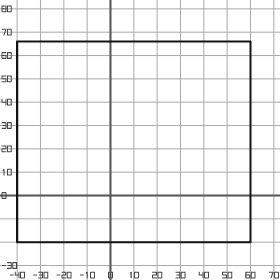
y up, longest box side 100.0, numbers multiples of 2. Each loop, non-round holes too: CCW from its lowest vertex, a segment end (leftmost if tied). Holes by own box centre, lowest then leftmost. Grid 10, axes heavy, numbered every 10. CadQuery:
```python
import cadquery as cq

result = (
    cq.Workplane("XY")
    .moveTo(-40.0, -20.0)
    .lineTo(60.0, -20.0)
    .lineTo(60.0, 66.0)
    .lineTo(-40.0, 66.0)
    .close()
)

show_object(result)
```